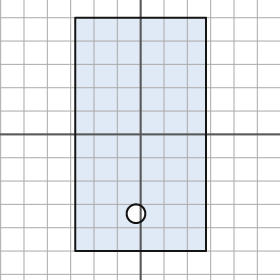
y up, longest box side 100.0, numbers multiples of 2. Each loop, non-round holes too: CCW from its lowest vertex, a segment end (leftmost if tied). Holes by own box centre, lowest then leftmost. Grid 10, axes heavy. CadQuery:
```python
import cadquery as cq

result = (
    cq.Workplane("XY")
    .moveTo(-28.0, -50.0)
    .lineTo(28.0, -50.0)
    .lineTo(28.0, 50.0)
    .lineTo(-28.0, 50.0)
    .close()
    .moveTo(-2.0, -34.0)
    .circle(4.0)
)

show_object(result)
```